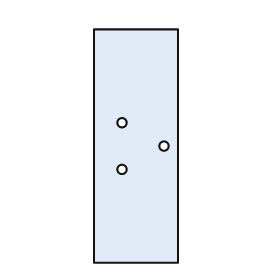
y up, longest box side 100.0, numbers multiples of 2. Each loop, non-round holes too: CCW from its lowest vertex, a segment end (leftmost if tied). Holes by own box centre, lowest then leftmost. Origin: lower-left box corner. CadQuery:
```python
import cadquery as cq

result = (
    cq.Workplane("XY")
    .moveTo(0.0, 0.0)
    .lineTo(36.0, 0.0)
    .lineTo(36.0, 100.0)
    .lineTo(0.0, 100.0)
    .close()
    .moveTo(12.0, 40.0)
    .circle(2.0)
    .moveTo(30.0, 50.0)
    .circle(2.0)
    .moveTo(12.0, 60.0)
    .circle(2.0)
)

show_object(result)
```